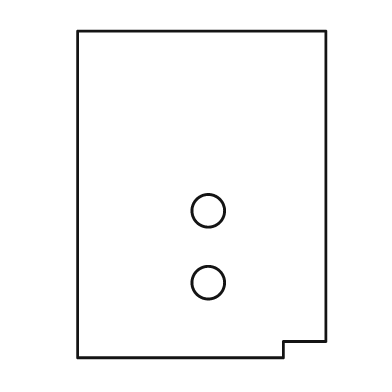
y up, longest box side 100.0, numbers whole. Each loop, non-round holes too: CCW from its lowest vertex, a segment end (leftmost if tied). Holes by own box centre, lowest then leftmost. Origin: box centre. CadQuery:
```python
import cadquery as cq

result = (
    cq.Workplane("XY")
    .moveTo(-38.0, -50.0)
    .lineTo(25.0, -50.0)
    .lineTo(25.0, -45.0)
    .lineTo(38.0, -45.0)
    .lineTo(38.0, 50.0)
    .lineTo(-38.0, 50.0)
    .close()
    .moveTo(2.0, -27.0)
    .circle(5.0)
    .moveTo(2.0, -5.0)
    .circle(5.0)
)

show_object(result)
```